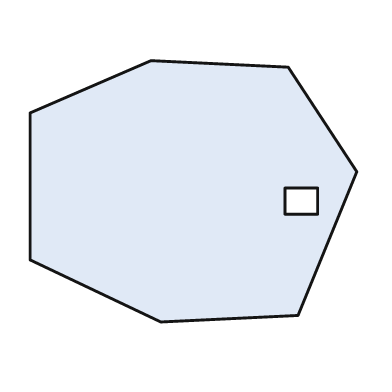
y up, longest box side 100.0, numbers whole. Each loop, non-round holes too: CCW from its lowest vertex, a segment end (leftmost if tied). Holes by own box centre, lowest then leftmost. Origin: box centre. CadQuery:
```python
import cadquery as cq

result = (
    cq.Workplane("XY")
    .moveTo(-10.0, -40.0)
    .lineTo(32.0, -38.0)
    .lineTo(50.0, 6.0)
    .lineTo(29.0, 38.0)
    .lineTo(-13.0, 40.0)
    .lineTo(-50.0, 24.0)
    .lineTo(-50.0, -21.0)
    .close()
    .moveTo(28.0, -7.0)
    .lineTo(38.0, -7.0)
    .lineTo(38.0, 1.0)
    .lineTo(28.0, 1.0)
    .close()
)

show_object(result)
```